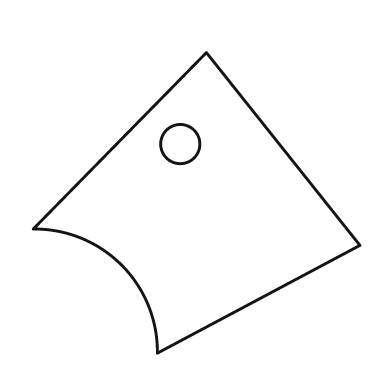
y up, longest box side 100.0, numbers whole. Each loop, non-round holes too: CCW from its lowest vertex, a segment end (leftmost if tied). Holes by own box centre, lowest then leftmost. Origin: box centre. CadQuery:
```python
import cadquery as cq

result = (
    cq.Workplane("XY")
    .moveTo(-12.0, -46.0)
    .lineTo(50.0, -13.0)
    .lineTo(3.0, 46.0)
    .lineTo(-50.0, -8.0)
    .threePointArc((-23.0, -19.0), (-12.0, -46.0))
    .close()
    .moveTo(-5.0, 18.0)
    .circle(6.0)
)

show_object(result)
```